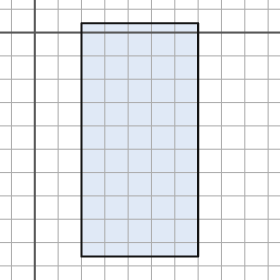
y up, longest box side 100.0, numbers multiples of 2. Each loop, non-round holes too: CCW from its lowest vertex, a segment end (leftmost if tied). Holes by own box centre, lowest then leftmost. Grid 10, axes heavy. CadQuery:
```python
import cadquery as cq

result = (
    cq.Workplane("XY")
    .moveTo(20.0, -96.0)
    .lineTo(70.0, -96.0)
    .lineTo(70.0, 4.0)
    .lineTo(20.0, 4.0)
    .close()
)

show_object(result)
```